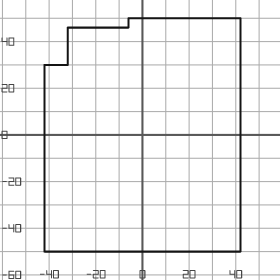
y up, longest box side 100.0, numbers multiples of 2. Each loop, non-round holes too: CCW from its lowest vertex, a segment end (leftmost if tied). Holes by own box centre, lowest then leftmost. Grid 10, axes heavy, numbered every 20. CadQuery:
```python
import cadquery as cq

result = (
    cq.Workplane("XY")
    .moveTo(-42.0, -50.0)
    .lineTo(42.0, -50.0)
    .lineTo(42.0, 50.0)
    .lineTo(-6.0, 50.0)
    .lineTo(-6.0, 46.0)
    .lineTo(-32.0, 46.0)
    .lineTo(-32.0, 30.0)
    .lineTo(-42.0, 30.0)
    .close()
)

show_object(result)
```